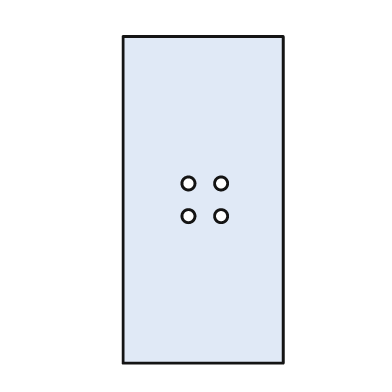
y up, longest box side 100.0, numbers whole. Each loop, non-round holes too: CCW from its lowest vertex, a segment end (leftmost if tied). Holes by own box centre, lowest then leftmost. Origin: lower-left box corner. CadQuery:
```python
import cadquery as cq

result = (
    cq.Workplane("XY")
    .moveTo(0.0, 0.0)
    .lineTo(49.0, 0.0)
    .lineTo(49.0, 100.0)
    .lineTo(0.0, 100.0)
    .close()
    .moveTo(20.0, 45.0)
    .circle(2.0)
    .moveTo(30.0, 45.0)
    .circle(2.0)
    .moveTo(20.0, 55.0)
    .circle(2.0)
    .moveTo(30.0, 55.0)
    .circle(2.0)
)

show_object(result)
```